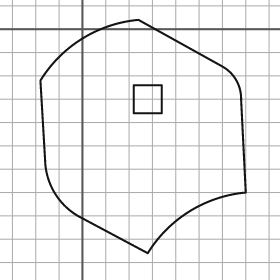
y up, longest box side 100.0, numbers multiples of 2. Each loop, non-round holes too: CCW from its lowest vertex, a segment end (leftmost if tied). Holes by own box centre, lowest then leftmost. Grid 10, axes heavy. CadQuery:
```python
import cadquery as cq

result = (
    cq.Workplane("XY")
    .moveTo(28.0, -96.0)
    .threePointArc((46.0, -78.0), (70.0, -70.0))
    .lineTo(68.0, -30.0)
    .threePointArc((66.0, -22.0), (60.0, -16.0))
    .lineTo(24.0, 4.0)
    .threePointArc((0.0, -4.0), (-18.0, -22.0))
    .lineTo(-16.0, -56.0)
    .threePointArc((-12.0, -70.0), (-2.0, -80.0))
    .close()
    .moveTo(22.0, -36.0)
    .lineTo(34.0, -36.0)
    .lineTo(34.0, -24.0)
    .lineTo(22.0, -24.0)
    .close()
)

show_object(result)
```